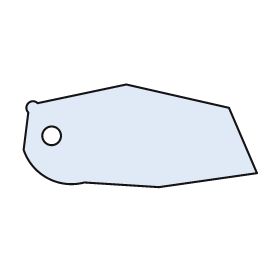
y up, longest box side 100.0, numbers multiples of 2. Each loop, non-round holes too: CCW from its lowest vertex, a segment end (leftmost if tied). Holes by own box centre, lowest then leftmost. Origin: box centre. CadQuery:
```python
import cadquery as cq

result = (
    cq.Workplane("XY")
    .moveTo(8.0, -22.0)
    .lineTo(50.0, -16.0)
    .lineTo(38.0, 12.0)
    .lineTo(-6.0, 22.0)
    .lineTo(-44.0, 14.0)
    .threePointArc((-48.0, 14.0), (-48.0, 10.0))
    .lineTo(-50.0, -6.0)
    .threePointArc((-40.0, -18.0), (-24.0, -20.0))
    .close()
    .moveTo(-38.0, 0.0)
    .circle(4.0)
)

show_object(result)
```